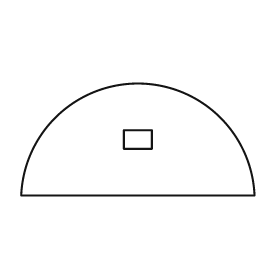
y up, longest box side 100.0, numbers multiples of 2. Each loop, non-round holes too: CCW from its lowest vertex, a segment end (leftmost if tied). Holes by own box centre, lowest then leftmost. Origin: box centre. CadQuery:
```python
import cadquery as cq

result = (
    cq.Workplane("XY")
    .moveTo(-50.0, -24.0)
    .lineTo(50.0, -24.0)
    .threePointArc((0.0, 24.0), (-50.0, -24.0))
    .close()
    .moveTo(-6.0, -4.0)
    .lineTo(6.0, -4.0)
    .lineTo(6.0, 4.0)
    .lineTo(-6.0, 4.0)
    .close()
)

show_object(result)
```